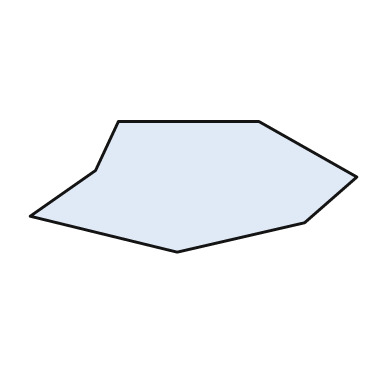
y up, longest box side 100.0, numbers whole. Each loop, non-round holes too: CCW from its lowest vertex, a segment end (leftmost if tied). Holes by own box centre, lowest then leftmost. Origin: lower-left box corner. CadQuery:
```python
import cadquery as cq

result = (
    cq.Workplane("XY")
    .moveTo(45.0, 0.0)
    .lineTo(84.0, 9.0)
    .lineTo(100.0, 23.0)
    .lineTo(70.0, 40.0)
    .lineTo(27.0, 40.0)
    .lineTo(20.0, 25.0)
    .lineTo(0.0, 11.0)
    .close()
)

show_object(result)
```